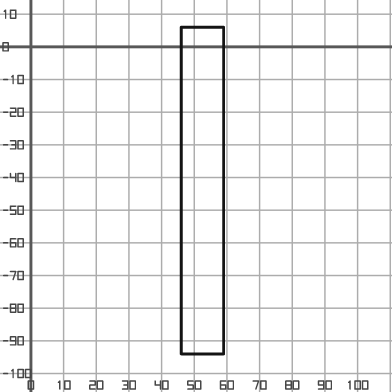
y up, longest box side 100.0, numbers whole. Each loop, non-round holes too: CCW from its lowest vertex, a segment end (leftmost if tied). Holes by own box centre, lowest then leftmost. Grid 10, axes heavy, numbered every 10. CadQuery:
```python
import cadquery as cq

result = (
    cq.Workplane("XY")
    .moveTo(46.0, -94.0)
    .lineTo(59.0, -94.0)
    .lineTo(59.0, 6.0)
    .lineTo(46.0, 6.0)
    .close()
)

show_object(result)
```